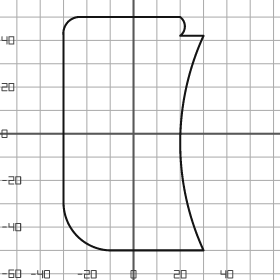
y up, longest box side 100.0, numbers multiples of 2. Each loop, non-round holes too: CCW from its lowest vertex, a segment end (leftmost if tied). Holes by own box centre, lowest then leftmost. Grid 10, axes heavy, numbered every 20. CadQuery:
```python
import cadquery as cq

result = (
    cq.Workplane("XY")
    .moveTo(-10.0, -50.0)
    .lineTo(30.0, -50.0)
    .threePointArc((20.0, -4.0), (30.0, 42.0))
    .lineTo(20.0, 42.0)
    .threePointArc((22.0, 46.0), (20.0, 50.0))
    .lineTo(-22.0, 50.0)
    .threePointArc((-28.0, 48.0), (-30.0, 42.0))
    .lineTo(-30.0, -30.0)
    .threePointArc((-24.0, -44.0), (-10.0, -50.0))
    .close()
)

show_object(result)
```